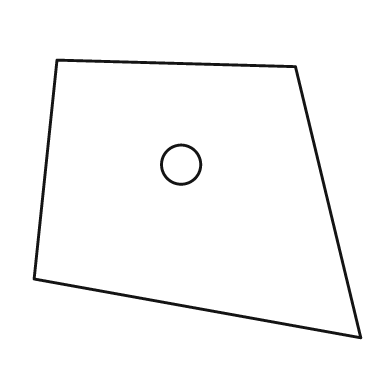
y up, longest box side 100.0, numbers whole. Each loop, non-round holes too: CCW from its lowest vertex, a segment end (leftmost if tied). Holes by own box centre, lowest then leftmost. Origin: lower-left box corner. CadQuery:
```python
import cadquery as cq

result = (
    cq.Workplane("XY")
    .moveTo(100.0, 0.0)
    .lineTo(80.0, 83.0)
    .lineTo(7.0, 85.0)
    .lineTo(0.0, 18.0)
    .close()
    .moveTo(45.0, 53.0)
    .circle(6.0)
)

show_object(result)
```